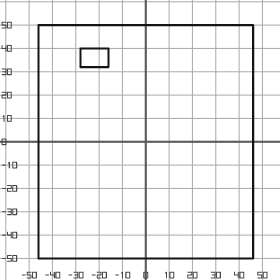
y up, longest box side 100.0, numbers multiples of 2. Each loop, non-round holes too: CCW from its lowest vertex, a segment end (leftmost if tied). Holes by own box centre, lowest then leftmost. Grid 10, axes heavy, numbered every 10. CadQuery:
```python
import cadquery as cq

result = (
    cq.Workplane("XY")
    .moveTo(-46.0, -50.0)
    .lineTo(46.0, -50.0)
    .lineTo(46.0, 50.0)
    .lineTo(-46.0, 50.0)
    .close()
    .moveTo(-28.0, 32.0)
    .lineTo(-16.0, 32.0)
    .lineTo(-16.0, 40.0)
    .lineTo(-28.0, 40.0)
    .close()
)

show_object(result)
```